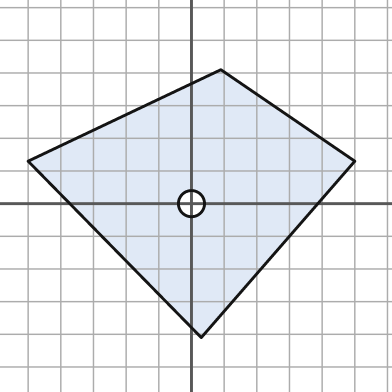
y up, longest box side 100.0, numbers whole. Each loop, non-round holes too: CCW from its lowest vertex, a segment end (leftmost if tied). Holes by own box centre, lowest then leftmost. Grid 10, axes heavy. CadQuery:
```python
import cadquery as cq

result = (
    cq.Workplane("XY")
    .moveTo(3.0, -41.0)
    .lineTo(50.0, 13.0)
    .lineTo(9.0, 41.0)
    .lineTo(-50.0, 13.0)
    .close()
    .moveTo(0.0, 0.0)
    .circle(4.0)
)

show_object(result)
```